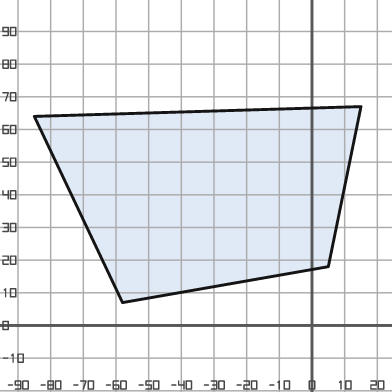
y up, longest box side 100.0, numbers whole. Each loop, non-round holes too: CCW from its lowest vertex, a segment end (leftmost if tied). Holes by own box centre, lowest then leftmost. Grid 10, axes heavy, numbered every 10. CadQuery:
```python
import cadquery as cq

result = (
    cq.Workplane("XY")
    .moveTo(-58.0, 7.0)
    .lineTo(5.0, 18.0)
    .lineTo(15.0, 67.0)
    .lineTo(-85.0, 64.0)
    .close()
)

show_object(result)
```